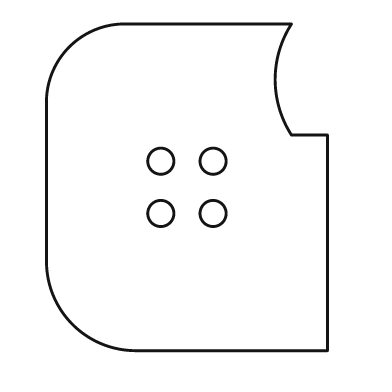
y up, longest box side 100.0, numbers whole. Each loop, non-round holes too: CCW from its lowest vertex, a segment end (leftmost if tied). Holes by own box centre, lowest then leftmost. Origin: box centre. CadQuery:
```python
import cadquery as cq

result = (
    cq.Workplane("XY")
    .moveTo(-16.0, -50.0)
    .lineTo(43.0, -50.0)
    .lineTo(43.0, 16.0)
    .lineTo(32.0, 16.0)
    .threePointArc((27.0, 33.0), (32.0, 50.0))
    .lineTo(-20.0, 50.0)
    .threePointArc((-36.0, 43.0), (-43.0, 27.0))
    .lineTo(-43.0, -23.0)
    .threePointArc((-35.0, -42.0), (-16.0, -50.0))
    .close()
    .moveTo(-8.0, -8.0)
    .circle(4.0)
    .moveTo(8.0, -8.0)
    .circle(4.0)
    .moveTo(-8.0, 8.0)
    .circle(4.0)
    .moveTo(8.0, 8.0)
    .circle(4.0)
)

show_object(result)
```